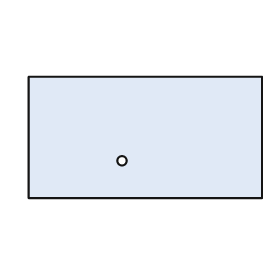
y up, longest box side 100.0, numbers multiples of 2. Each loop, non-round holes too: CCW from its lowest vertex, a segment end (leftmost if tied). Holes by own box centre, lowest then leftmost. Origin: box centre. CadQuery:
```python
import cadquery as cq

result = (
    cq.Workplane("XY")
    .moveTo(-50.0, -26.0)
    .lineTo(50.0, -26.0)
    .lineTo(50.0, 26.0)
    .lineTo(-50.0, 26.0)
    .close()
    .moveTo(-10.0, -10.0)
    .circle(2.0)
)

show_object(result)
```